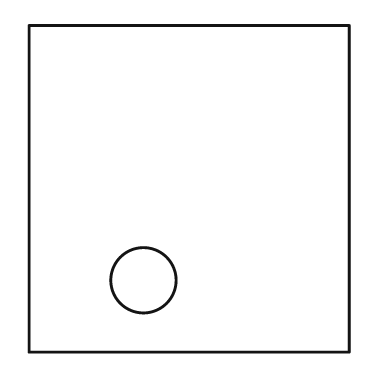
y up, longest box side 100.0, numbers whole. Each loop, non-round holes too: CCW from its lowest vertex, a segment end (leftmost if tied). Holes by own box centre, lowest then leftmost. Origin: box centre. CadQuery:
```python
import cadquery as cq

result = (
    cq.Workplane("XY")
    .moveTo(-49.0, -50.0)
    .lineTo(49.0, -50.0)
    .lineTo(49.0, 50.0)
    .lineTo(-49.0, 50.0)
    .close()
    .moveTo(-14.0, -28.0)
    .circle(10.0)
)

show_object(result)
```